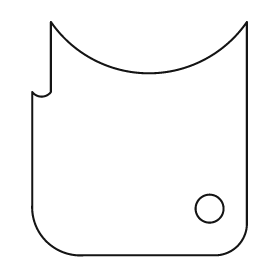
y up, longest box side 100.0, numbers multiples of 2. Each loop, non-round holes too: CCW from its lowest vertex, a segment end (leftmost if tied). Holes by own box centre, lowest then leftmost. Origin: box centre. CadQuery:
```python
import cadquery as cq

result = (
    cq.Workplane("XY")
    .moveTo(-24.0, -50.0)
    .lineTo(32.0, -50.0)
    .threePointArc((42.0, -46.0), (46.0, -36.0))
    .lineTo(46.0, 50.0)
    .threePointArc((4.0, 28.0), (-38.0, 50.0))
    .lineTo(-38.0, 20.0)
    .threePointArc((-42.0, 18.0), (-46.0, 20.0))
    .lineTo(-46.0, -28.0)
    .threePointArc((-40.0, -44.0), (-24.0, -50.0))
    .close()
    .moveTo(30.0, -30.0)
    .circle(6.0)
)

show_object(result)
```